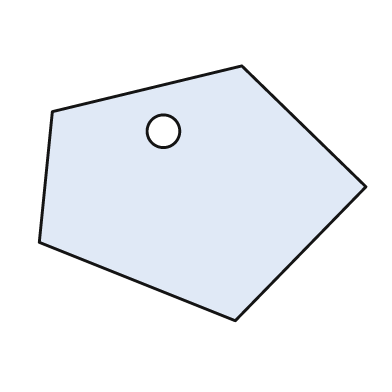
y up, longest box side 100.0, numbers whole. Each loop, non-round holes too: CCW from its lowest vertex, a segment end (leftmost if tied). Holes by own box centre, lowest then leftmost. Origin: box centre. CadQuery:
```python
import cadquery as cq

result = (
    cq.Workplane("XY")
    .moveTo(10.0, -39.0)
    .lineTo(50.0, 2.0)
    .lineTo(12.0, 39.0)
    .lineTo(-46.0, 25.0)
    .lineTo(-50.0, -15.0)
    .close()
    .moveTo(-12.0, 19.0)
    .circle(5.0)
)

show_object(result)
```